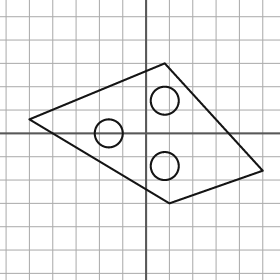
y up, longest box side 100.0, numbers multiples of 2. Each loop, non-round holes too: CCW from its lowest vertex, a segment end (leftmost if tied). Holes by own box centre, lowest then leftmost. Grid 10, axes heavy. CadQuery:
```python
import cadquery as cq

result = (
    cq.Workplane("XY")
    .moveTo(10.0, -30.0)
    .lineTo(50.0, -16.0)
    .lineTo(8.0, 30.0)
    .lineTo(-50.0, 6.0)
    .close()
    .moveTo(8.0, -14.0)
    .circle(6.0)
    .moveTo(-16.0, 0.0)
    .circle(6.0)
    .moveTo(8.0, 14.0)
    .circle(6.0)
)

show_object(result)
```